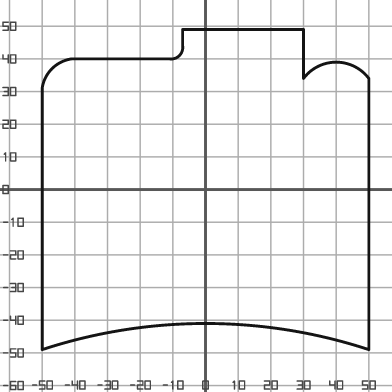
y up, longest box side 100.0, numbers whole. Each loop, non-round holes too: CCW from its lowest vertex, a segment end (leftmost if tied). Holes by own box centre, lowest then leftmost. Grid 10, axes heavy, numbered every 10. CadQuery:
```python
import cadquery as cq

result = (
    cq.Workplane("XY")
    .moveTo(-50.0, -49.0)
    .threePointArc((0.0, -41.0), (50.0, -49.0))
    .lineTo(50.0, 34.0)
    .threePointArc((40.0, 39.0), (30.0, 34.0))
    .lineTo(30.0, 49.0)
    .lineTo(-7.0, 49.0)
    .lineTo(-7.0, 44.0)
    .threePointArc((-8.0, 41.0), (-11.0, 40.0))
    .lineTo(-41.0, 40.0)
    .threePointArc((-47.0, 37.0), (-50.0, 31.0))
    .close()
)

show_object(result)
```